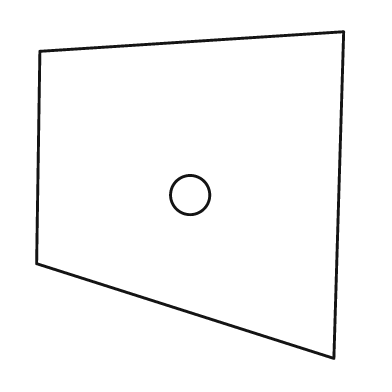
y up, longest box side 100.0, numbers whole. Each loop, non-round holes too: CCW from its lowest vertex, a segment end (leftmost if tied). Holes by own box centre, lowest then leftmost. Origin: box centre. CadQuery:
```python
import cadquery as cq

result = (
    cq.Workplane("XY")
    .moveTo(44.0, -50.0)
    .lineTo(47.0, 50.0)
    .lineTo(-46.0, 44.0)
    .lineTo(-47.0, -21.0)
    .close()
    .moveTo(0.0, 0.0)
    .circle(6.0)
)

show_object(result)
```